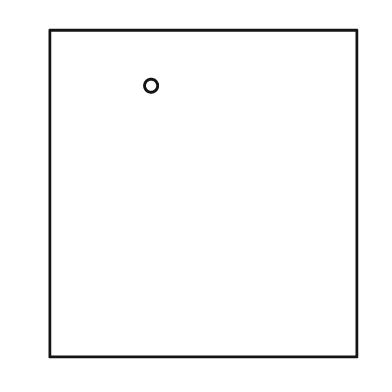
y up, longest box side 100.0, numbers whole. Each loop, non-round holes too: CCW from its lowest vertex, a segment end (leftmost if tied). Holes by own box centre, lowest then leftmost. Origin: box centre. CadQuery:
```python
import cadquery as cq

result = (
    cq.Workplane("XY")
    .moveTo(-47.0, -50.0)
    .lineTo(47.0, -50.0)
    .lineTo(47.0, 50.0)
    .lineTo(-47.0, 50.0)
    .close()
    .moveTo(-16.0, 33.0)
    .circle(2.0)
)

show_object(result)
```